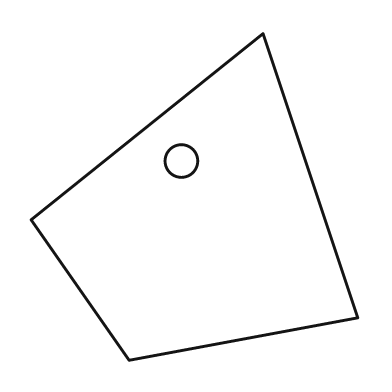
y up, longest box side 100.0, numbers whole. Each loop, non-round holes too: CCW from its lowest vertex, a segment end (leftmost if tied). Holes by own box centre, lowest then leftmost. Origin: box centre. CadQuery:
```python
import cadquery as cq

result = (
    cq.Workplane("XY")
    .moveTo(-20.0, -50.0)
    .lineTo(50.0, -37.0)
    .lineTo(21.0, 50.0)
    .lineTo(-50.0, -7.0)
    .close()
    .moveTo(-4.0, 11.0)
    .circle(5.0)
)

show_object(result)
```